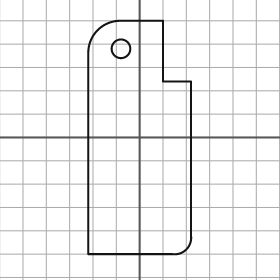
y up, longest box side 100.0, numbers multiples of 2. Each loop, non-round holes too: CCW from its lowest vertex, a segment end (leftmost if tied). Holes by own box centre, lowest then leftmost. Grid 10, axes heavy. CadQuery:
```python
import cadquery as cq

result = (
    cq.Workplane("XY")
    .moveTo(-22.0, -50.0)
    .lineTo(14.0, -50.0)
    .threePointArc((20.0, -48.0), (22.0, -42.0))
    .lineTo(22.0, 24.0)
    .lineTo(10.0, 24.0)
    .lineTo(10.0, 50.0)
    .lineTo(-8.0, 50.0)
    .threePointArc((-18.0, 46.0), (-22.0, 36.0))
    .close()
    .moveTo(-8.0, 38.0)
    .circle(4.0)
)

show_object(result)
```